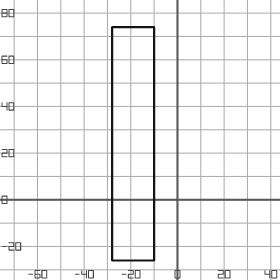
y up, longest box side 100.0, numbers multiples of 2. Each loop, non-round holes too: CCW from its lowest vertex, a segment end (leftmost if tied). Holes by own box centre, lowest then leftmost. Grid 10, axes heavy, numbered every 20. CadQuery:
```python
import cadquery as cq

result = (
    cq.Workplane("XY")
    .moveTo(-28.0, -26.0)
    .lineTo(-10.0, -26.0)
    .lineTo(-10.0, 74.0)
    .lineTo(-28.0, 74.0)
    .close()
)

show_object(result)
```